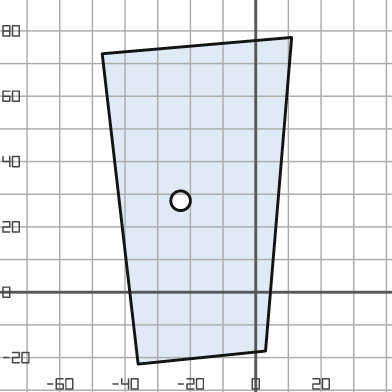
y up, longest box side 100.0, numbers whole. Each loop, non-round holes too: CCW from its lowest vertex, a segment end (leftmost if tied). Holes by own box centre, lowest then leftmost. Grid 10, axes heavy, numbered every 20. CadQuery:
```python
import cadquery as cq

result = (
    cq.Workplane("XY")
    .moveTo(-36.0, -22.0)
    .lineTo(3.0, -18.0)
    .lineTo(11.0, 78.0)
    .lineTo(-47.0, 73.0)
    .close()
    .moveTo(-23.0, 28.0)
    .circle(3.0)
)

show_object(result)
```